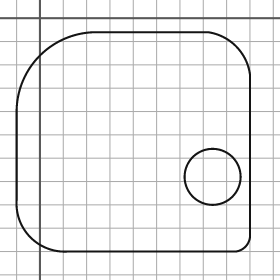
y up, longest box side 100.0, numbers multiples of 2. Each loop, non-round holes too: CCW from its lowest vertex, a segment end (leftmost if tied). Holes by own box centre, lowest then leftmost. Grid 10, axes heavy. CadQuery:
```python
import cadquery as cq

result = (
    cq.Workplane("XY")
    .moveTo(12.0, -100.0)
    .lineTo(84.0, -100.0)
    .threePointArc((88.0, -98.0), (90.0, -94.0))
    .lineTo(90.0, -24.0)
    .threePointArc((84.0, -12.0), (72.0, -6.0))
    .lineTo(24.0, -6.0)
    .threePointArc((0.0, -16.0), (-10.0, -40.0))
    .lineTo(-10.0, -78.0)
    .threePointArc((-4.0, -94.0), (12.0, -100.0))
    .close()
    .moveTo(74.0, -68.0)
    .circle(12.0)
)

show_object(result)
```